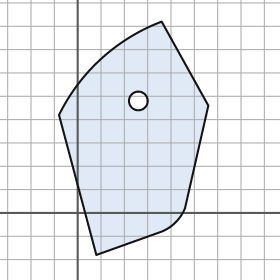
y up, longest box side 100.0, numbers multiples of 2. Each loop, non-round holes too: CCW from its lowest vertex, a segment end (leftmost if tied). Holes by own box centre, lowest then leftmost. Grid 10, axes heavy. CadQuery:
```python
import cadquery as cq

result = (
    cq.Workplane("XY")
    .moveTo(8.0, -18.0)
    .lineTo(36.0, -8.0)
    .threePointArc((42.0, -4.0), (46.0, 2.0))
    .lineTo(56.0, 46.0)
    .lineTo(36.0, 82.0)
    .threePointArc((10.0, 66.0), (-8.0, 42.0))
    .close()
    .moveTo(26.0, 48.0)
    .circle(4.0)
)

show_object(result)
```